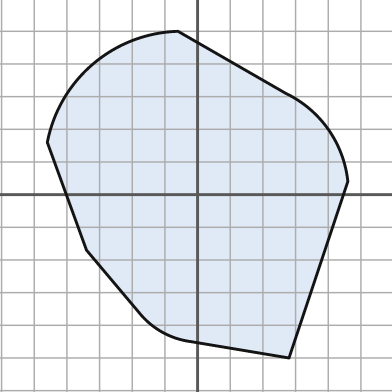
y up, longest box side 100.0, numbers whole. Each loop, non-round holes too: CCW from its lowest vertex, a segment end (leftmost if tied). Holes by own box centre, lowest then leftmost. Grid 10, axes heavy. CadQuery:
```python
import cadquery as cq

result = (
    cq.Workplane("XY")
    .moveTo(28.0, -50.0)
    .lineTo(46.0, 4.0)
    .threePointArc((40.0, 20.0), (27.0, 31.0))
    .lineTo(-6.0, 50.0)
    .threePointArc((-32.0, 40.0), (-46.0, 16.0))
    .lineTo(-34.0, -17.0)
    .lineTo(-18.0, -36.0)
    .threePointArc((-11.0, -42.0), (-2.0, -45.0))
    .close()
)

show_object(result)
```